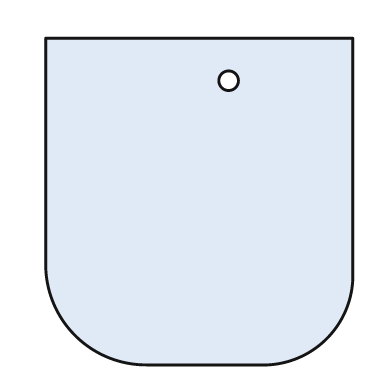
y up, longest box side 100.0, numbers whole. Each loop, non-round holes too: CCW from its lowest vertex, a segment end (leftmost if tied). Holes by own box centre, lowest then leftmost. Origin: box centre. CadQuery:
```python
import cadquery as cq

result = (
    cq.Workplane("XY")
    .moveTo(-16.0, -50.0)
    .lineTo(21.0, -50.0)
    .threePointArc((39.0, -42.0), (47.0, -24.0))
    .lineTo(47.0, 50.0)
    .lineTo(-47.0, 50.0)
    .lineTo(-47.0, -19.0)
    .threePointArc((-38.0, -41.0), (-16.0, -50.0))
    .close()
    .moveTo(9.0, 37.0)
    .circle(3.0)
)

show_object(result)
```